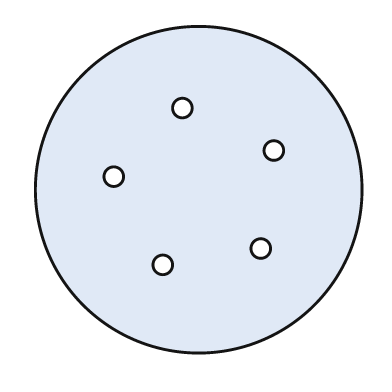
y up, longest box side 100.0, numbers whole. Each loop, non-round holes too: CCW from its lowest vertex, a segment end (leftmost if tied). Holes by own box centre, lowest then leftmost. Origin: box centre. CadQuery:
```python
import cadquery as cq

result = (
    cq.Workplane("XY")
    .moveTo(0.0, 0.0)
    .circle(50.0)
    .moveTo(-11.0, -23.0)
    .circle(3.0)
    .moveTo(19.0, -18.0)
    .circle(3.0)
    .moveTo(-26.0, 4.0)
    .circle(3.0)
    .moveTo(23.0, 12.0)
    .circle(3.0)
    .moveTo(-5.0, 25.0)
    .circle(3.0)
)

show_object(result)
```